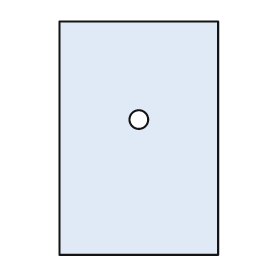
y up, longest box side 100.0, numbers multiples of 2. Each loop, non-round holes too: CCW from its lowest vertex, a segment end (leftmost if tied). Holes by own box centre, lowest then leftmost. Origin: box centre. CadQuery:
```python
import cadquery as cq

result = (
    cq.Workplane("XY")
    .moveTo(-34.0, -50.0)
    .lineTo(34.0, -50.0)
    .lineTo(34.0, 50.0)
    .lineTo(-34.0, 50.0)
    .close()
    .moveTo(0.0, 8.0)
    .circle(4.0)
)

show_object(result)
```